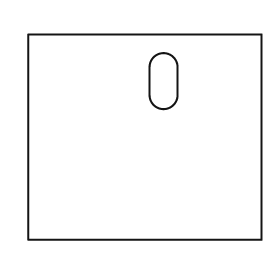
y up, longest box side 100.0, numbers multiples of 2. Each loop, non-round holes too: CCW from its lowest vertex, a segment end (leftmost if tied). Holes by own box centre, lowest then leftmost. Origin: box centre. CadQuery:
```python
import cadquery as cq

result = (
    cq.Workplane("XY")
    .moveTo(-50.0, -44.0)
    .lineTo(50.0, -44.0)
    .lineTo(50.0, 44.0)
    .lineTo(-50.0, 44.0)
    .close()
    .moveTo(2.0, 18.0)
    .threePointArc((8.0, 12.0), (14.0, 18.0))
    .lineTo(14.0, 30.0)
    .threePointArc((8.0, 36.0), (2.0, 30.0))
    .close()
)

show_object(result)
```